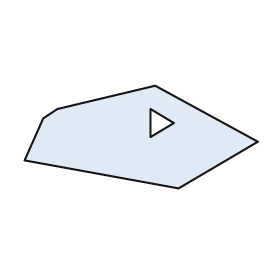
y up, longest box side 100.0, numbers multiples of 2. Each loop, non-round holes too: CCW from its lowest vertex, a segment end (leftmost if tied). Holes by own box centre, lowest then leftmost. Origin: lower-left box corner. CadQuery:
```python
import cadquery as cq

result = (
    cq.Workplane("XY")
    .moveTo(66.0, 0.0)
    .lineTo(100.0, 20.0)
    .lineTo(56.0, 44.0)
    .lineTo(14.0, 34.0)
    .lineTo(8.0, 30.0)
    .lineTo(0.0, 12.0)
    .close()
    .moveTo(54.0, 22.0)
    .lineTo(64.0, 28.0)
    .lineTo(54.0, 34.0)
    .close()
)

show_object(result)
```